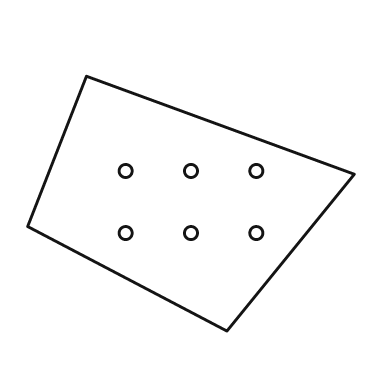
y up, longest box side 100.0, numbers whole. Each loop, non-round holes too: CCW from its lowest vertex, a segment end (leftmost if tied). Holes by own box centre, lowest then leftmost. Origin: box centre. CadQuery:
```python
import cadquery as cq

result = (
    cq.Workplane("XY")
    .moveTo(11.0, -39.0)
    .lineTo(50.0, 9.0)
    .lineTo(-32.0, 39.0)
    .lineTo(-50.0, -7.0)
    .close()
    .moveTo(-20.0, -9.0)
    .circle(2.0)
    .moveTo(0.0, -9.0)
    .circle(2.0)
    .moveTo(20.0, -9.0)
    .circle(2.0)
    .moveTo(-20.0, 10.0)
    .circle(2.0)
    .moveTo(0.0, 10.0)
    .circle(2.0)
    .moveTo(20.0, 10.0)
    .circle(2.0)
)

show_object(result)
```